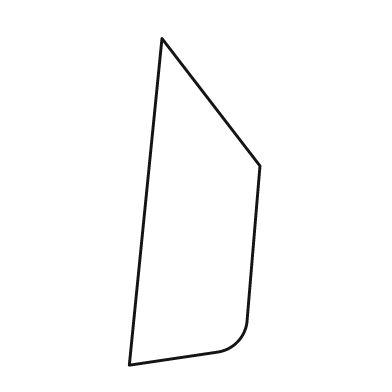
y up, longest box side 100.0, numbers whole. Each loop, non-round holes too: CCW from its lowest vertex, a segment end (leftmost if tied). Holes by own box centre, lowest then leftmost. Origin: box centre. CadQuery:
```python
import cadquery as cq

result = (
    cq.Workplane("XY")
    .moveTo(-20.0, -50.0)
    .lineTo(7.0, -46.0)
    .threePointArc((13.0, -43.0), (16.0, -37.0))
    .lineTo(20.0, 11.0)
    .lineTo(-10.0, 50.0)
    .close()
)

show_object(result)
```